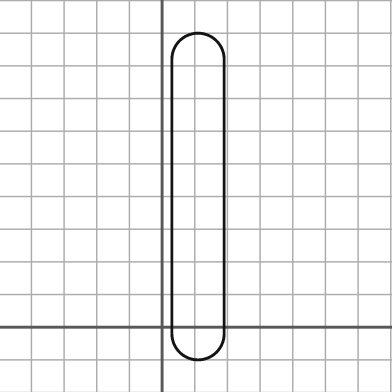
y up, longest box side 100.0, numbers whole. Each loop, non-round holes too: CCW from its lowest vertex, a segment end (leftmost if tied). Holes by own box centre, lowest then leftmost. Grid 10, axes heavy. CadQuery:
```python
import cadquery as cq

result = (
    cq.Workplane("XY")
    .moveTo(3.0, -2.0)
    .threePointArc((11.0, -10.0), (19.0, -2.0))
    .lineTo(19.0, 82.0)
    .threePointArc((11.0, 90.0), (3.0, 82.0))
    .close()
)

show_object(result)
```